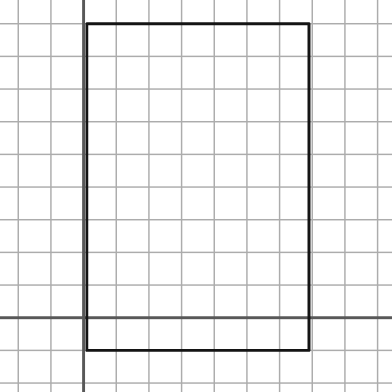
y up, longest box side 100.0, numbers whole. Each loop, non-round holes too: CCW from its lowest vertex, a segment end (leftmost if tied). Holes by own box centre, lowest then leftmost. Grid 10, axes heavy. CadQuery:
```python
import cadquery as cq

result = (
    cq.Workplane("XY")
    .moveTo(1.0, -10.0)
    .lineTo(69.0, -10.0)
    .lineTo(69.0, 90.0)
    .lineTo(1.0, 90.0)
    .close()
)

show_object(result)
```